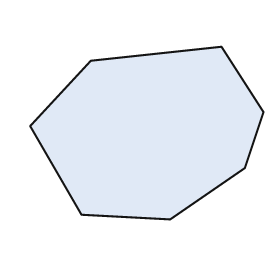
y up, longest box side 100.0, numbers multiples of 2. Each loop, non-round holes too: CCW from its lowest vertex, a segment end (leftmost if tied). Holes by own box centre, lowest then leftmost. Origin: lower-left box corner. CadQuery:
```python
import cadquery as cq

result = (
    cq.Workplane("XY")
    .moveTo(60.0, 0.0)
    .lineTo(92.0, 22.0)
    .lineTo(100.0, 46.0)
    .lineTo(82.0, 74.0)
    .lineTo(26.0, 68.0)
    .lineTo(0.0, 40.0)
    .lineTo(22.0, 2.0)
    .close()
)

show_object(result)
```